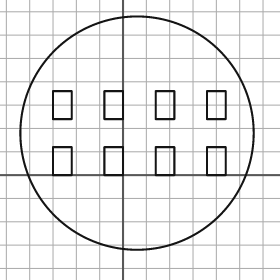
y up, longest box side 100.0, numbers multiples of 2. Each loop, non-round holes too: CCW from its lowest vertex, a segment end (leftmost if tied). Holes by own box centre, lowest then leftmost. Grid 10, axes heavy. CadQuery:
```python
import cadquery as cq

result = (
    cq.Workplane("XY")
    .moveTo(6.0, 18.0)
    .circle(50.0)
    .moveTo(-30.0, 0.0)
    .lineTo(-22.0, 0.0)
    .lineTo(-22.0, 12.0)
    .lineTo(-30.0, 12.0)
    .close()
    .moveTo(-8.0, 0.0)
    .lineTo(0.0, 0.0)
    .lineTo(0.0, 12.0)
    .lineTo(-8.0, 12.0)
    .close()
    .moveTo(14.0, 0.0)
    .lineTo(22.0, 0.0)
    .lineTo(22.0, 12.0)
    .lineTo(14.0, 12.0)
    .close()
    .moveTo(36.0, 0.0)
    .lineTo(44.0, 0.0)
    .lineTo(44.0, 12.0)
    .lineTo(36.0, 12.0)
    .close()
    .moveTo(-30.0, 24.0)
    .lineTo(-22.0, 24.0)
    .lineTo(-22.0, 36.0)
    .lineTo(-30.0, 36.0)
    .close()
    .moveTo(-8.0, 24.0)
    .lineTo(0.0, 24.0)
    .lineTo(0.0, 36.0)
    .lineTo(-8.0, 36.0)
    .close()
    .moveTo(14.0, 24.0)
    .lineTo(22.0, 24.0)
    .lineTo(22.0, 36.0)
    .lineTo(14.0, 36.0)
    .close()
    .moveTo(36.0, 24.0)
    .lineTo(44.0, 24.0)
    .lineTo(44.0, 36.0)
    .lineTo(36.0, 36.0)
    .close()
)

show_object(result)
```